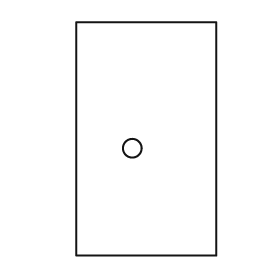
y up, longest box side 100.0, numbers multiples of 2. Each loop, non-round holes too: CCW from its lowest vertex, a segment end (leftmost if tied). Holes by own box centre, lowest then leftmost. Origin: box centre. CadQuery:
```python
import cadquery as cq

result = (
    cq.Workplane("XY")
    .moveTo(-30.0, -50.0)
    .lineTo(30.0, -50.0)
    .lineTo(30.0, 50.0)
    .lineTo(-30.0, 50.0)
    .close()
    .moveTo(-6.0, -4.0)
    .circle(4.0)
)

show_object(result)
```